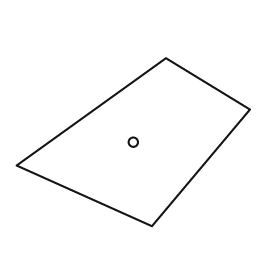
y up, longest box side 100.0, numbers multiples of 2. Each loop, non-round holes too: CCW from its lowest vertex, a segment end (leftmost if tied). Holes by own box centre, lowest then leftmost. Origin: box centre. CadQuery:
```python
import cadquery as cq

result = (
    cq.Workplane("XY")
    .moveTo(8.0, -36.0)
    .lineTo(50.0, 14.0)
    .lineTo(14.0, 36.0)
    .lineTo(-50.0, -10.0)
    .close()
    .moveTo(0.0, 0.0)
    .circle(2.0)
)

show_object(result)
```